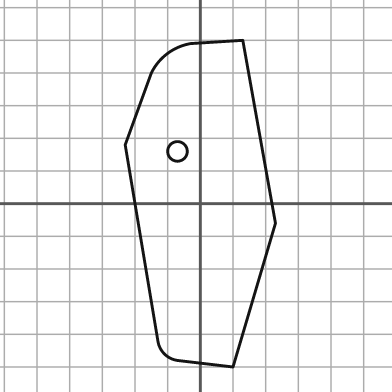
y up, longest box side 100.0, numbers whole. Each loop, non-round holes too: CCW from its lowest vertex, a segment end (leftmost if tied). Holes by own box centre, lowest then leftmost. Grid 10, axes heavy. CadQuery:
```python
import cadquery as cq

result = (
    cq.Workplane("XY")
    .moveTo(10.0, -50.0)
    .lineTo(23.0, -6.0)
    .lineTo(13.0, 50.0)
    .lineTo(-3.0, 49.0)
    .threePointArc((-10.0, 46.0), (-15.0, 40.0))
    .lineTo(-23.0, 18.0)
    .lineTo(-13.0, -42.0)
    .threePointArc((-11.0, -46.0), (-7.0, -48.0))
    .close()
    .moveTo(-7.0, 16.0)
    .circle(3.0)
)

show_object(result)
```